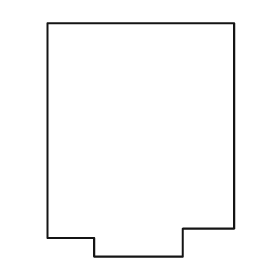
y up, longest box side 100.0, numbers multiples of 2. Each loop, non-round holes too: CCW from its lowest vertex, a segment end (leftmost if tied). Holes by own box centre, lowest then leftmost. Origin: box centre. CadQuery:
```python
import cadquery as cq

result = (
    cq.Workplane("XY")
    .moveTo(-20.0, -50.0)
    .lineTo(18.0, -50.0)
    .lineTo(18.0, -38.0)
    .lineTo(40.0, -38.0)
    .lineTo(40.0, 50.0)
    .lineTo(-40.0, 50.0)
    .lineTo(-40.0, -42.0)
    .lineTo(-20.0, -42.0)
    .close()
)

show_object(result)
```